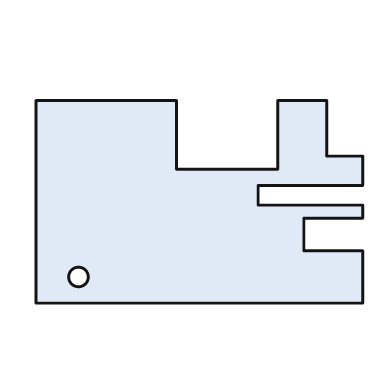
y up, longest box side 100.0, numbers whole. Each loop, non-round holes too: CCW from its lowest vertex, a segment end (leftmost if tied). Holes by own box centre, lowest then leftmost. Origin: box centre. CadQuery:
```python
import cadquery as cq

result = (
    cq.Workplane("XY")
    .moveTo(-50.0, -31.0)
    .lineTo(50.0, -31.0)
    .lineTo(50.0, -15.0)
    .lineTo(32.0, -15.0)
    .lineTo(32.0, -5.0)
    .lineTo(50.0, -5.0)
    .lineTo(50.0, -1.0)
    .lineTo(18.0, -1.0)
    .lineTo(18.0, 5.0)
    .lineTo(50.0, 5.0)
    .lineTo(50.0, 14.0)
    .lineTo(39.0, 14.0)
    .lineTo(39.0, 31.0)
    .lineTo(24.0, 31.0)
    .lineTo(24.0, 10.0)
    .lineTo(-7.0, 10.0)
    .lineTo(-7.0, 31.0)
    .lineTo(-50.0, 31.0)
    .close()
    .moveTo(-37.0, -23.0)
    .circle(3.0)
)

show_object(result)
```